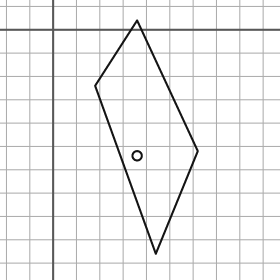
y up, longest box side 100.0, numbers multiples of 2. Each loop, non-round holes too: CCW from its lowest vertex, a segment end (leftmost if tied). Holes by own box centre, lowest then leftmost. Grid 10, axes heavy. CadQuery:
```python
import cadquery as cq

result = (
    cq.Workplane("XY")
    .moveTo(44.0, -96.0)
    .lineTo(62.0, -52.0)
    .lineTo(36.0, 4.0)
    .lineTo(18.0, -24.0)
    .close()
    .moveTo(36.0, -54.0)
    .circle(2.0)
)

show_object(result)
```